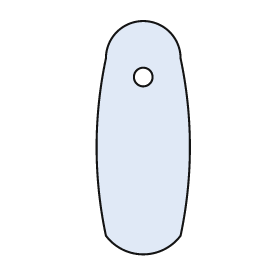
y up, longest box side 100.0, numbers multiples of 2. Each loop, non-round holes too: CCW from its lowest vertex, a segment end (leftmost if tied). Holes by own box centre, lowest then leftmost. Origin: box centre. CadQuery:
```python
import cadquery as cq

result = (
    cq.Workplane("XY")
    .moveTo(-16.0, -42.0)
    .threePointArc((0.0, -50.0), (16.0, -42.0))
    .threePointArc((20.0, -4.0), (16.0, 34.0))
    .threePointArc((0.0, 50.0), (-16.0, 34.0))
    .threePointArc((-20.0, -4.0), (-16.0, -42.0))
    .close()
    .moveTo(0.0, 26.0)
    .circle(4.0)
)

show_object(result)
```